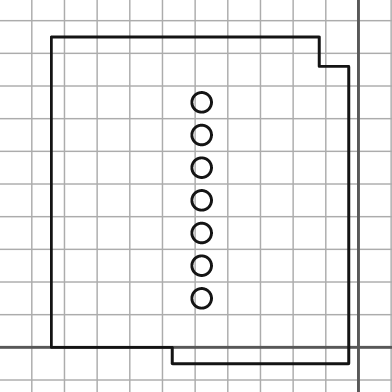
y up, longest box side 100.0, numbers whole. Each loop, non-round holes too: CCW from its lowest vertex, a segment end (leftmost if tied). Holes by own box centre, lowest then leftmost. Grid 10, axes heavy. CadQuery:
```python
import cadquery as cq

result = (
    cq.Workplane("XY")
    .moveTo(-57.0, -5.0)
    .lineTo(-3.0, -5.0)
    .lineTo(-3.0, 86.0)
    .lineTo(-12.0, 86.0)
    .lineTo(-12.0, 95.0)
    .lineTo(-94.0, 95.0)
    .lineTo(-94.0, 0.0)
    .lineTo(-57.0, 0.0)
    .close()
    .moveTo(-48.0, 15.0)
    .circle(3.0)
    .moveTo(-48.0, 25.0)
    .circle(3.0)
    .moveTo(-48.0, 35.0)
    .circle(3.0)
    .moveTo(-48.0, 45.0)
    .circle(3.0)
    .moveTo(-48.0, 55.0)
    .circle(3.0)
    .moveTo(-48.0, 65.0)
    .circle(3.0)
    .moveTo(-48.0, 75.0)
    .circle(3.0)
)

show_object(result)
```